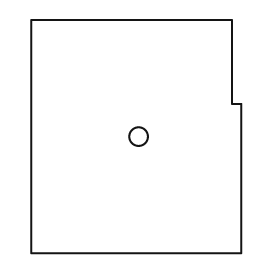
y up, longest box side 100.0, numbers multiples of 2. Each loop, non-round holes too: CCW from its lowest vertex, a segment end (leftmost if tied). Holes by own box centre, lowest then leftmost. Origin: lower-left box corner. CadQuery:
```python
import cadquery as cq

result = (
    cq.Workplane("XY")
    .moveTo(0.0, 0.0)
    .lineTo(90.0, 0.0)
    .lineTo(90.0, 64.0)
    .lineTo(86.0, 64.0)
    .lineTo(86.0, 100.0)
    .lineTo(0.0, 100.0)
    .close()
    .moveTo(46.0, 50.0)
    .circle(4.0)
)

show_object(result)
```